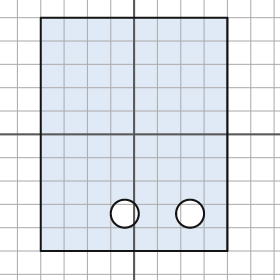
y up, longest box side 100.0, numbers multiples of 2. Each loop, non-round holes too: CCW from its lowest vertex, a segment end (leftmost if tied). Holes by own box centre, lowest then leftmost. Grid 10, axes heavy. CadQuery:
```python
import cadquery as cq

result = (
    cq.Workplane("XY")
    .moveTo(-40.0, -50.0)
    .lineTo(40.0, -50.0)
    .lineTo(40.0, 50.0)
    .lineTo(-40.0, 50.0)
    .close()
    .moveTo(-4.0, -34.0)
    .circle(6.0)
    .moveTo(24.0, -34.0)
    .circle(6.0)
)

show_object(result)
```